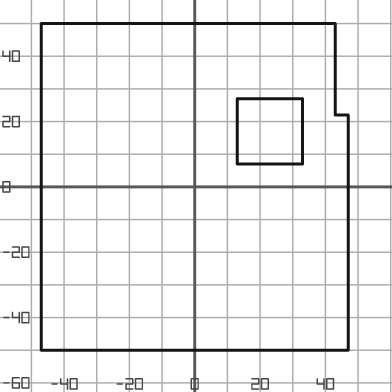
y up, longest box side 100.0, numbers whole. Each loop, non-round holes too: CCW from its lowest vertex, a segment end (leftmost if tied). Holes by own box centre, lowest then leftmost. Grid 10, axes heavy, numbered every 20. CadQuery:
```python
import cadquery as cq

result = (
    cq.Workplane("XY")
    .moveTo(-47.0, -50.0)
    .lineTo(47.0, -50.0)
    .lineTo(47.0, 22.0)
    .lineTo(43.0, 22.0)
    .lineTo(43.0, 50.0)
    .lineTo(-47.0, 50.0)
    .close()
    .moveTo(13.0, 7.0)
    .lineTo(33.0, 7.0)
    .lineTo(33.0, 27.0)
    .lineTo(13.0, 27.0)
    .close()
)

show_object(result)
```